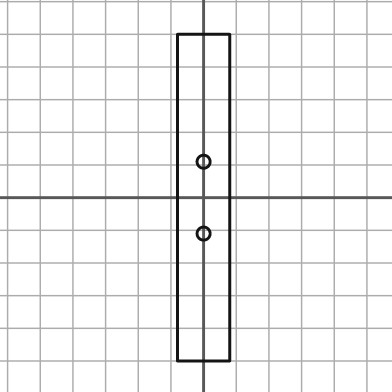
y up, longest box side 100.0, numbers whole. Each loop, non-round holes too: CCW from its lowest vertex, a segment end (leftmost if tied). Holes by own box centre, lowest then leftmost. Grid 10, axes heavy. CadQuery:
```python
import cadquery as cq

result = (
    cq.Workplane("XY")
    .moveTo(-8.0, -50.0)
    .lineTo(8.0, -50.0)
    .lineTo(8.0, 50.0)
    .lineTo(-8.0, 50.0)
    .close()
    .moveTo(0.0, -11.0)
    .circle(2.0)
    .moveTo(0.0, 11.0)
    .circle(2.0)
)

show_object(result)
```